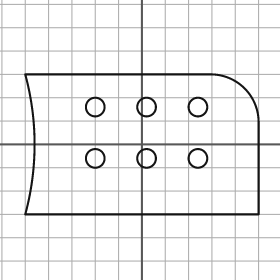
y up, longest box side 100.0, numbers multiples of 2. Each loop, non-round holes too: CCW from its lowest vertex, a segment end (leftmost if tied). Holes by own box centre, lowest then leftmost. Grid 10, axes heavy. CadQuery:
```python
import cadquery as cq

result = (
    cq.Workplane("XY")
    .moveTo(-50.0, -30.0)
    .lineTo(50.0, -30.0)
    .lineTo(50.0, 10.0)
    .threePointArc((44.0, 24.0), (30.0, 30.0))
    .lineTo(-50.0, 30.0)
    .threePointArc((-46.0, 0.0), (-50.0, -30.0))
    .close()
    .moveTo(-20.0, -6.0)
    .circle(4.0)
    .moveTo(2.0, -6.0)
    .circle(4.0)
    .moveTo(24.0, -6.0)
    .circle(4.0)
    .moveTo(-20.0, 16.0)
    .circle(4.0)
    .moveTo(2.0, 16.0)
    .circle(4.0)
    .moveTo(24.0, 16.0)
    .circle(4.0)
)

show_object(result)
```